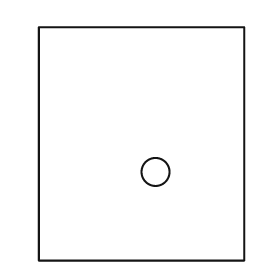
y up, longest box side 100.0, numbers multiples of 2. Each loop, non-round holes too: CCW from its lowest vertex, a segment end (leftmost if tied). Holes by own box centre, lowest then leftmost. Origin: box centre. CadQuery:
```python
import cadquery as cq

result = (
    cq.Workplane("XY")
    .moveTo(-44.0, -50.0)
    .lineTo(44.0, -50.0)
    .lineTo(44.0, 50.0)
    .lineTo(-44.0, 50.0)
    .close()
    .moveTo(6.0, -12.0)
    .circle(6.0)
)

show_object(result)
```